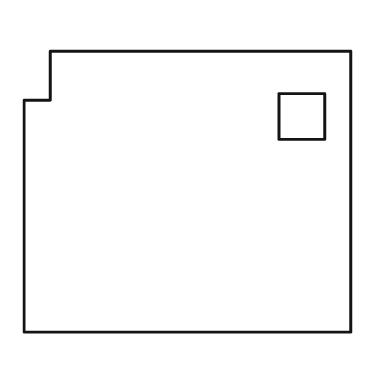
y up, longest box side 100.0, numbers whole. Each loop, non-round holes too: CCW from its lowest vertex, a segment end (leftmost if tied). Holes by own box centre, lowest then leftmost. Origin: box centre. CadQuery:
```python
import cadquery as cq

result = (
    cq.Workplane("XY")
    .moveTo(-50.0, -43.0)
    .lineTo(50.0, -43.0)
    .lineTo(50.0, 43.0)
    .lineTo(-42.0, 43.0)
    .lineTo(-42.0, 28.0)
    .lineTo(-50.0, 28.0)
    .close()
    .moveTo(28.0, 16.0)
    .lineTo(42.0, 16.0)
    .lineTo(42.0, 30.0)
    .lineTo(28.0, 30.0)
    .close()
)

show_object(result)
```